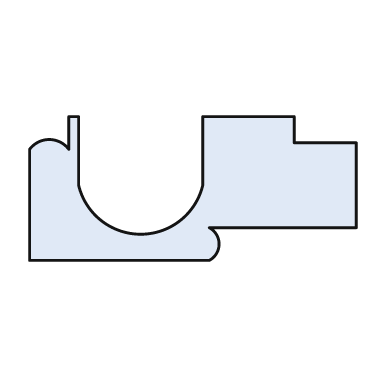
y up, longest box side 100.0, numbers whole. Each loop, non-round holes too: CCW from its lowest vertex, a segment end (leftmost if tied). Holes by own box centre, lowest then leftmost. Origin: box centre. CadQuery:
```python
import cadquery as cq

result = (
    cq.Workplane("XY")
    .moveTo(-50.0, -22.0)
    .lineTo(5.0, -22.0)
    .threePointArc((8.0, -17.0), (5.0, -12.0))
    .lineTo(50.0, -12.0)
    .lineTo(50.0, 14.0)
    .lineTo(31.0, 14.0)
    .lineTo(31.0, 22.0)
    .lineTo(3.0, 22.0)
    .lineTo(3.0, 1.0)
    .threePointArc((-16.0, -14.0), (-35.0, 1.0))
    .lineTo(-35.0, 22.0)
    .lineTo(-38.0, 22.0)
    .lineTo(-38.0, 12.0)
    .threePointArc((-44.0, 15.0), (-50.0, 12.0))
    .close()
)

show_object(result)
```